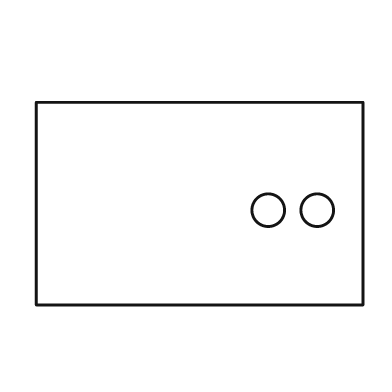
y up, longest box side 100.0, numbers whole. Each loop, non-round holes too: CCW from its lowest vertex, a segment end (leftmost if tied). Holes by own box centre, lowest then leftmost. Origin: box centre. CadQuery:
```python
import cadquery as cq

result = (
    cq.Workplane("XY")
    .moveTo(-50.0, -31.0)
    .lineTo(50.0, -31.0)
    .lineTo(50.0, 31.0)
    .lineTo(-50.0, 31.0)
    .close()
    .moveTo(21.0, -2.0)
    .circle(5.0)
    .moveTo(36.0, -2.0)
    .circle(5.0)
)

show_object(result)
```